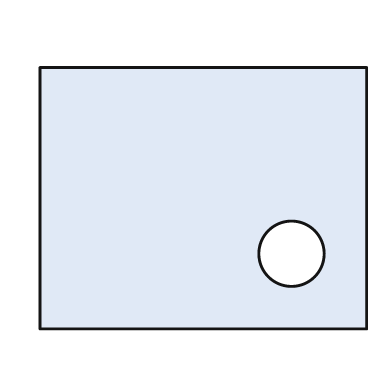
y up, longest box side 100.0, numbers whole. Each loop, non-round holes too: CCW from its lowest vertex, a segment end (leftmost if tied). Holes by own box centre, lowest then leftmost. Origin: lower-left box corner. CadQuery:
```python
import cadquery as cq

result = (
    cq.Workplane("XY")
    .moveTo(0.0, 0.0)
    .lineTo(100.0, 0.0)
    .lineTo(100.0, 80.0)
    .lineTo(0.0, 80.0)
    .close()
    .moveTo(77.0, 23.0)
    .circle(10.0)
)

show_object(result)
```